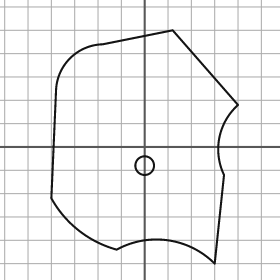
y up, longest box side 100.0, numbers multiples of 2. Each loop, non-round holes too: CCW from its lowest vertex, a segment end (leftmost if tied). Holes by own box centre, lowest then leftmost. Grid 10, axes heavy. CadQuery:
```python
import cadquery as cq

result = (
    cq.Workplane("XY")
    .moveTo(30.0, -50.0)
    .lineTo(34.0, -12.0)
    .threePointArc((32.0, 4.0), (40.0, 18.0))
    .lineTo(12.0, 50.0)
    .lineTo(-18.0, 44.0)
    .threePointArc((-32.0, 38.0), (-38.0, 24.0))
    .lineTo(-40.0, -22.0)
    .threePointArc((-28.0, -36.0), (-12.0, -44.0))
    .threePointArc((10.0, -40.0), (30.0, -50.0))
    .close()
    .moveTo(0.0, -8.0)
    .circle(4.0)
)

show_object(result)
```